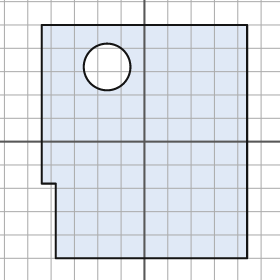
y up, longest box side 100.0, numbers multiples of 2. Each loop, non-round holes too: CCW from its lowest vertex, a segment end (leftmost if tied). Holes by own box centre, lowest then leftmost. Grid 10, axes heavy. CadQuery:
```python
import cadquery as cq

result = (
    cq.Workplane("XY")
    .moveTo(-38.0, -50.0)
    .lineTo(44.0, -50.0)
    .lineTo(44.0, 50.0)
    .lineTo(-44.0, 50.0)
    .lineTo(-44.0, -18.0)
    .lineTo(-38.0, -18.0)
    .close()
    .moveTo(-16.0, 32.0)
    .circle(10.0)
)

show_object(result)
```